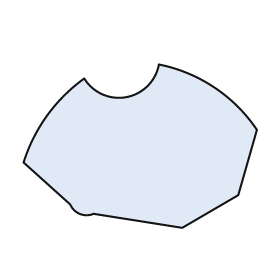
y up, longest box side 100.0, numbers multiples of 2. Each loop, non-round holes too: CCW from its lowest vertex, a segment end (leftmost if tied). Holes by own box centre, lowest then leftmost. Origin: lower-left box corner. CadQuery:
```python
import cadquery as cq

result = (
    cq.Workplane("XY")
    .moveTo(68.0, 0.0)
    .lineTo(92.0, 14.0)
    .lineTo(100.0, 42.0)
    .threePointArc((82.0, 60.0), (58.0, 70.0))
    .threePointArc((44.0, 56.0), (26.0, 64.0))
    .threePointArc((10.0, 48.0), (0.0, 28.0))
    .lineTo(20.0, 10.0)
    .threePointArc((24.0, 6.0), (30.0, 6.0))
    .close()
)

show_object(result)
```